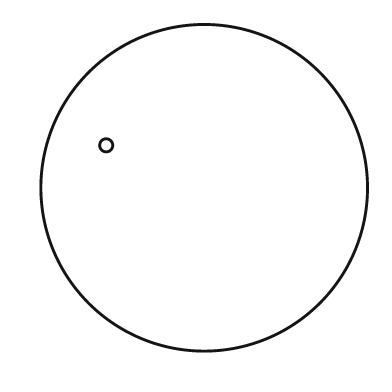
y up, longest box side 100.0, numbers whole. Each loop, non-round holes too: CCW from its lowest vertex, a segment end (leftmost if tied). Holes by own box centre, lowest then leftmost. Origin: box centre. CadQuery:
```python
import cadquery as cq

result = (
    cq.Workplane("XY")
    .moveTo(0.0, 0.0)
    .circle(50.0)
    .moveTo(-30.0, 13.0)
    .circle(2.0)
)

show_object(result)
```